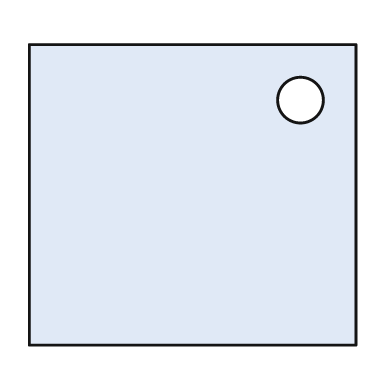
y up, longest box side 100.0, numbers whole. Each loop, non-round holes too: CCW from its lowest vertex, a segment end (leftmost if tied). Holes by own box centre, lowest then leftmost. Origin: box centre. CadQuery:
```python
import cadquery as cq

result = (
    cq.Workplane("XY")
    .moveTo(-50.0, -46.0)
    .lineTo(50.0, -46.0)
    .lineTo(50.0, 46.0)
    .lineTo(-50.0, 46.0)
    .close()
    .moveTo(33.0, 29.0)
    .circle(7.0)
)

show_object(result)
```